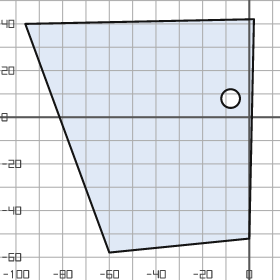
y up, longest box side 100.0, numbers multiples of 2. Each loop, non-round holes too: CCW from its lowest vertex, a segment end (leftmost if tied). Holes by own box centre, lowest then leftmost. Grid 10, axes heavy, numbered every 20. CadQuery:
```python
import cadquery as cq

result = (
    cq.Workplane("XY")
    .moveTo(-60.0, -58.0)
    .lineTo(0.0, -52.0)
    .lineTo(2.0, 42.0)
    .lineTo(-96.0, 40.0)
    .close()
    .moveTo(-8.0, 8.0)
    .circle(4.0)
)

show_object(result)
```